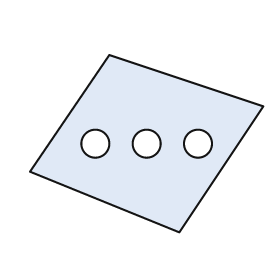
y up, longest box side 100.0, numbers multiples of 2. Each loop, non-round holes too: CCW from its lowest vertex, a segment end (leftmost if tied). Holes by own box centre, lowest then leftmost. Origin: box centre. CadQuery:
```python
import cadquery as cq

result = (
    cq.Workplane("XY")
    .moveTo(14.0, -38.0)
    .lineTo(50.0, 16.0)
    .lineTo(-16.0, 38.0)
    .lineTo(-50.0, -12.0)
    .close()
    .moveTo(-22.0, 0.0)
    .circle(6.0)
    .moveTo(0.0, 0.0)
    .circle(6.0)
    .moveTo(22.0, 0.0)
    .circle(6.0)
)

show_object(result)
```